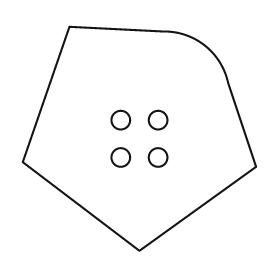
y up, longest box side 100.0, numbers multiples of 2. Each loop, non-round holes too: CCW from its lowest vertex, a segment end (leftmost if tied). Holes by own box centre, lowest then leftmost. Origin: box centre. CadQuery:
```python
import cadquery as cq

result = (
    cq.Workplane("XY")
    .moveTo(0.0, -48.0)
    .lineTo(50.0, -12.0)
    .lineTo(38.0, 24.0)
    .threePointArc((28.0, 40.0), (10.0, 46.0))
    .lineTo(-30.0, 48.0)
    .lineTo(-50.0, -10.0)
    .close()
    .moveTo(-8.0, -8.0)
    .circle(4.0)
    .moveTo(8.0, -8.0)
    .circle(4.0)
    .moveTo(-8.0, 8.0)
    .circle(4.0)
    .moveTo(8.0, 8.0)
    .circle(4.0)
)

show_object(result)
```